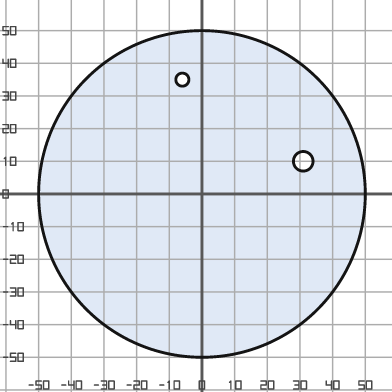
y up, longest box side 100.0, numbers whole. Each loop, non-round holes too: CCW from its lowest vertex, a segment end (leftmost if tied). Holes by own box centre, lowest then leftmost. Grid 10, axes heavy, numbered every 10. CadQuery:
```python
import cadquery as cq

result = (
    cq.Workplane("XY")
    .moveTo(0.0, 0.0)
    .circle(50.0)
    .moveTo(31.0, 10.0)
    .circle(3.0)
    .moveTo(-6.0, 35.0)
    .circle(2.0)
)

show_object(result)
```